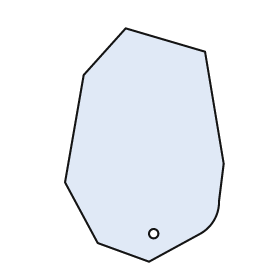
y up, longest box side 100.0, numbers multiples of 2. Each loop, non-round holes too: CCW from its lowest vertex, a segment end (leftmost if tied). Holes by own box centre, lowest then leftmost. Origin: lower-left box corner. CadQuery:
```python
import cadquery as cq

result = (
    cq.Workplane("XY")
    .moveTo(36.0, 0.0)
    .lineTo(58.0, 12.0)
    .threePointArc((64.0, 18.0), (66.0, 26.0))
    .lineTo(68.0, 42.0)
    .lineTo(60.0, 90.0)
    .lineTo(26.0, 100.0)
    .lineTo(8.0, 80.0)
    .lineTo(0.0, 34.0)
    .lineTo(14.0, 8.0)
    .close()
    .moveTo(38.0, 12.0)
    .circle(2.0)
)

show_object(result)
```